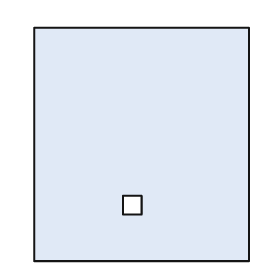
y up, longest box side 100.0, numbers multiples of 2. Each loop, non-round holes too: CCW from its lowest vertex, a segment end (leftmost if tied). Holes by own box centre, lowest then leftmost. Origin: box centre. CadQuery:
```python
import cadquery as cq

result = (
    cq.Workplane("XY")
    .moveTo(-46.0, -50.0)
    .lineTo(46.0, -50.0)
    .lineTo(46.0, 50.0)
    .lineTo(-46.0, 50.0)
    .close()
    .moveTo(-8.0, -30.0)
    .lineTo(0.0, -30.0)
    .lineTo(0.0, -22.0)
    .lineTo(-8.0, -22.0)
    .close()
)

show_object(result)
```